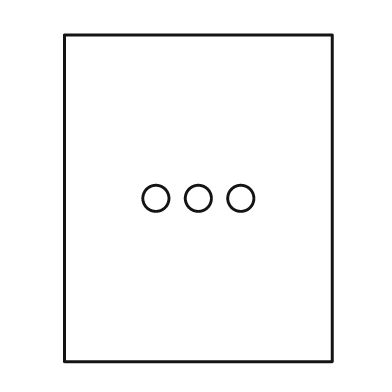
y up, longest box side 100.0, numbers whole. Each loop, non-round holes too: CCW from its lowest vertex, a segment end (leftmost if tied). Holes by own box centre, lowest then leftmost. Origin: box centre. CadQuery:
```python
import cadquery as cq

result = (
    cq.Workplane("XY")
    .moveTo(-41.0, -50.0)
    .lineTo(41.0, -50.0)
    .lineTo(41.0, 50.0)
    .lineTo(-41.0, 50.0)
    .close()
    .moveTo(-13.0, 0.0)
    .circle(4.0)
    .moveTo(0.0, 0.0)
    .circle(4.0)
    .moveTo(13.0, 0.0)
    .circle(4.0)
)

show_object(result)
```